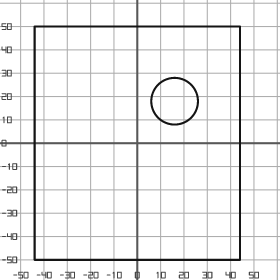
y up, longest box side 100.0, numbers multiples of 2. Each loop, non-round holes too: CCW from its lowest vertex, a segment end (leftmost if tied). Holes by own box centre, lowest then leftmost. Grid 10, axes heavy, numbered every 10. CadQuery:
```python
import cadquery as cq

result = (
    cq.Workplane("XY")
    .moveTo(-44.0, -50.0)
    .lineTo(44.0, -50.0)
    .lineTo(44.0, 50.0)
    .lineTo(-44.0, 50.0)
    .close()
    .moveTo(16.0, 18.0)
    .circle(10.0)
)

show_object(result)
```